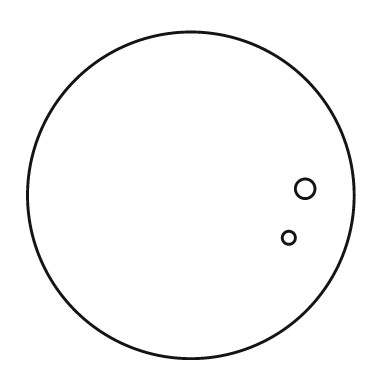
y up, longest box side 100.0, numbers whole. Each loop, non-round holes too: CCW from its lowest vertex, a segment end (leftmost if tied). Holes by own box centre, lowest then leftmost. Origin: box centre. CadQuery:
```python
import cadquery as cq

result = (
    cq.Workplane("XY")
    .moveTo(0.0, 0.0)
    .circle(50.0)
    .moveTo(30.0, -13.0)
    .circle(2.0)
    .moveTo(35.0, 2.0)
    .circle(3.0)
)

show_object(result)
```